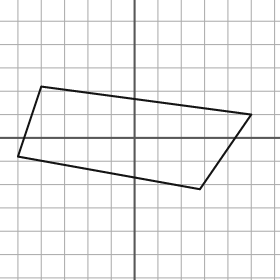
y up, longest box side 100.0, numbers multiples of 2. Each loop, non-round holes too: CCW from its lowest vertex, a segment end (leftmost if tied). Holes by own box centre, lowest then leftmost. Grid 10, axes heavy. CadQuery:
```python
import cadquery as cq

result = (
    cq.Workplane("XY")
    .moveTo(28.0, -22.0)
    .lineTo(50.0, 10.0)
    .lineTo(-40.0, 22.0)
    .lineTo(-50.0, -8.0)
    .close()
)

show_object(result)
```